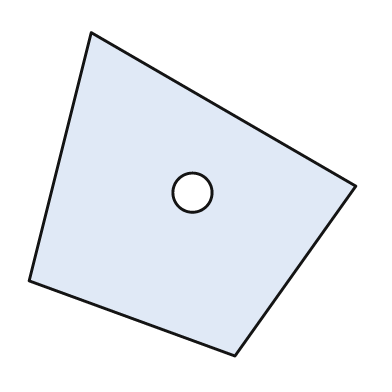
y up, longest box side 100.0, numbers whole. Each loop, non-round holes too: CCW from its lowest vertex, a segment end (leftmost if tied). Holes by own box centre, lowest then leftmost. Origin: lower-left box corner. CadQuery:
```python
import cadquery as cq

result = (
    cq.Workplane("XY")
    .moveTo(63.0, 0.0)
    .lineTo(100.0, 52.0)
    .lineTo(19.0, 99.0)
    .lineTo(0.0, 23.0)
    .close()
    .moveTo(50.0, 50.0)
    .circle(6.0)
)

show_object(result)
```